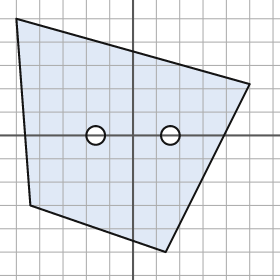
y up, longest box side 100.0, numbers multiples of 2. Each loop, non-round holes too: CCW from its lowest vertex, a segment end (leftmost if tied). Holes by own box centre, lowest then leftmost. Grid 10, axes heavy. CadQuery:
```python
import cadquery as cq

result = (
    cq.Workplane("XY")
    .moveTo(14.0, -50.0)
    .lineTo(50.0, 22.0)
    .lineTo(-50.0, 50.0)
    .lineTo(-44.0, -30.0)
    .close()
    .moveTo(-16.0, 0.0)
    .circle(4.0)
    .moveTo(16.0, 0.0)
    .circle(4.0)
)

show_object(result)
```